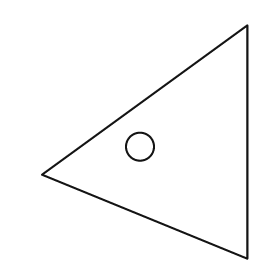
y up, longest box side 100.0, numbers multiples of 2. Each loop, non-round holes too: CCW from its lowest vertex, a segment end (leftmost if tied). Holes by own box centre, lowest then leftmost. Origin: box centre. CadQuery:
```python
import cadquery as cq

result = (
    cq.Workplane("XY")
    .moveTo(44.0, -50.0)
    .lineTo(44.0, 50.0)
    .lineTo(-44.0, -14.0)
    .close()
    .moveTo(-2.0, -2.0)
    .circle(6.0)
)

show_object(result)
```